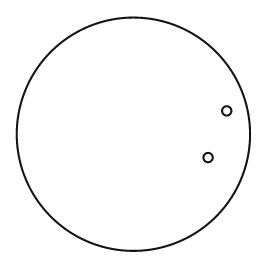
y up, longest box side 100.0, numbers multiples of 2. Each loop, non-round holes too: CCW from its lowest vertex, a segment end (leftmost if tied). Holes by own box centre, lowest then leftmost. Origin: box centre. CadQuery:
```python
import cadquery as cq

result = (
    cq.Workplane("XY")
    .moveTo(0.0, 0.0)
    .circle(50.0)
    .moveTo(32.0, -10.0)
    .circle(2.0)
    .moveTo(40.0, 10.0)
    .circle(2.0)
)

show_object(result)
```